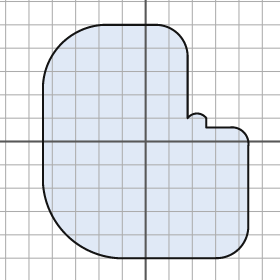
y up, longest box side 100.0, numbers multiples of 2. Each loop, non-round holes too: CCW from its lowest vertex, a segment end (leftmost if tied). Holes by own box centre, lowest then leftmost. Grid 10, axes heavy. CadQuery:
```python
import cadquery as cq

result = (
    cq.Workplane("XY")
    .moveTo(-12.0, -50.0)
    .lineTo(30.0, -50.0)
    .threePointArc((40.0, -46.0), (44.0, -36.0))
    .lineTo(44.0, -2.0)
    .threePointArc((42.0, 4.0), (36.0, 6.0))
    .lineTo(26.0, 6.0)
    .lineTo(26.0, 10.0)
    .threePointArc((22.0, 12.0), (18.0, 10.0))
    .lineTo(18.0, 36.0)
    .threePointArc((14.0, 46.0), (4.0, 50.0))
    .lineTo(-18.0, 50.0)
    .threePointArc((-36.0, 42.0), (-44.0, 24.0))
    .lineTo(-44.0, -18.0)
    .threePointArc((-34.0, -40.0), (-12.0, -50.0))
    .close()
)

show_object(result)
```